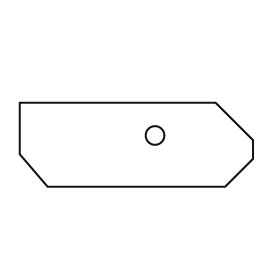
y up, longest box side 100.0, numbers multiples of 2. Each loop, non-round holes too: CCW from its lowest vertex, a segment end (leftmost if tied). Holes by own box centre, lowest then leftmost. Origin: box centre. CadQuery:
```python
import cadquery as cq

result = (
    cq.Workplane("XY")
    .moveTo(-38.0, -18.0)
    .lineTo(38.0, -18.0)
    .lineTo(50.0, -6.0)
    .lineTo(50.0, 2.0)
    .lineTo(34.0, 18.0)
    .lineTo(-50.0, 18.0)
    .lineTo(-50.0, -4.0)
    .close()
    .moveTo(8.0, 4.0)
    .circle(4.0)
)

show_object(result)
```